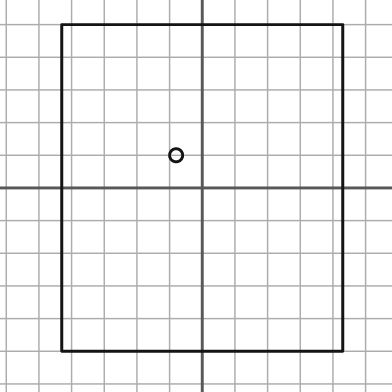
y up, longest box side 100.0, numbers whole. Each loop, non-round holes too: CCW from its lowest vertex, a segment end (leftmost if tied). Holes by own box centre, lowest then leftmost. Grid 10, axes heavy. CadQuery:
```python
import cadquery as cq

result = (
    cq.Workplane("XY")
    .moveTo(-43.0, -50.0)
    .lineTo(43.0, -50.0)
    .lineTo(43.0, 50.0)
    .lineTo(-43.0, 50.0)
    .close()
    .moveTo(-8.0, 10.0)
    .circle(2.0)
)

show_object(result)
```